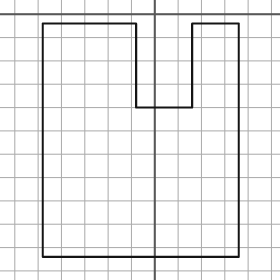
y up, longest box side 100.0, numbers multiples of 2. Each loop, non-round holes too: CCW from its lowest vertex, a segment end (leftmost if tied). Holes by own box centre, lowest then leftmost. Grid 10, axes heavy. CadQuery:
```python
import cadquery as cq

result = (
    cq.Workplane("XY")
    .moveTo(-48.0, -104.0)
    .lineTo(36.0, -104.0)
    .lineTo(36.0, -4.0)
    .lineTo(16.0, -4.0)
    .lineTo(16.0, -40.0)
    .lineTo(-8.0, -40.0)
    .lineTo(-8.0, -4.0)
    .lineTo(-48.0, -4.0)
    .close()
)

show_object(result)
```